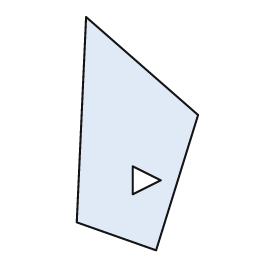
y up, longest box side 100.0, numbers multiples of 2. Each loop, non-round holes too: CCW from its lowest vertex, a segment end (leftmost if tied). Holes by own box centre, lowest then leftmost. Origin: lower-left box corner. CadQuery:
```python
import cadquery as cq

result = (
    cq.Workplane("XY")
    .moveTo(34.0, 0.0)
    .lineTo(52.0, 58.0)
    .lineTo(4.0, 100.0)
    .lineTo(0.0, 12.0)
    .close()
    .moveTo(24.0, 24.0)
    .lineTo(36.0, 30.0)
    .lineTo(24.0, 36.0)
    .close()
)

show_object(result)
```